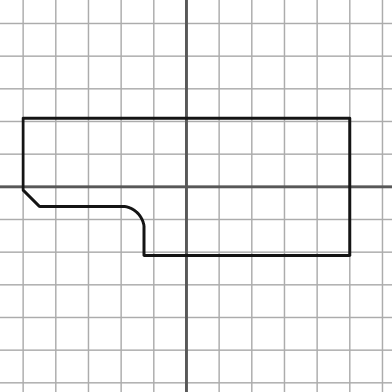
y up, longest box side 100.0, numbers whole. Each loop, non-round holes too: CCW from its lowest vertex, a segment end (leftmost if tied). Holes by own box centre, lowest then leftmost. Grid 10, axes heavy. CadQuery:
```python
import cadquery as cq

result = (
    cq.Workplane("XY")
    .moveTo(-13.0, -21.0)
    .lineTo(50.0, -21.0)
    .lineTo(50.0, 21.0)
    .lineTo(-50.0, 21.0)
    .lineTo(-50.0, -1.0)
    .lineTo(-45.0, -6.0)
    .lineTo(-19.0, -6.0)
    .threePointArc((-15.0, -8.0), (-13.0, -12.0))
    .close()
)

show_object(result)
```